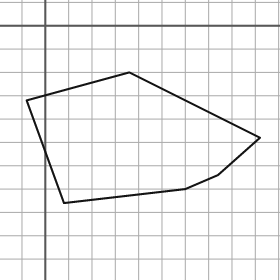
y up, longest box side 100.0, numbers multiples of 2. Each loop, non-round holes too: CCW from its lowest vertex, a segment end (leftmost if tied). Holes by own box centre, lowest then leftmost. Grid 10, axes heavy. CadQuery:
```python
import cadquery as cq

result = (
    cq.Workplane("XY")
    .moveTo(8.0, -76.0)
    .lineTo(60.0, -70.0)
    .lineTo(74.0, -64.0)
    .lineTo(92.0, -48.0)
    .lineTo(36.0, -20.0)
    .lineTo(-8.0, -32.0)
    .close()
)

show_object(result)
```